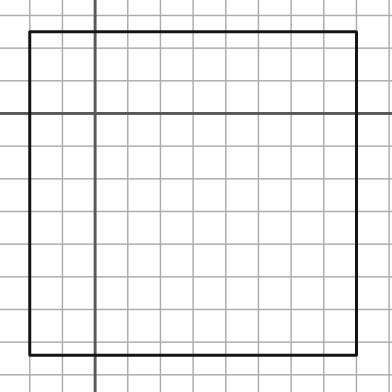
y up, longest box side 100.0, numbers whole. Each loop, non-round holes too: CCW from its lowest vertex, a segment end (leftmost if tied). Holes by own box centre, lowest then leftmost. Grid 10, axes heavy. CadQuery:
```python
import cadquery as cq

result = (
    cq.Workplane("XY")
    .moveTo(-20.0, -74.0)
    .lineTo(80.0, -74.0)
    .lineTo(80.0, 25.0)
    .lineTo(-20.0, 25.0)
    .close()
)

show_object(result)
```